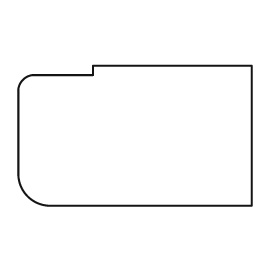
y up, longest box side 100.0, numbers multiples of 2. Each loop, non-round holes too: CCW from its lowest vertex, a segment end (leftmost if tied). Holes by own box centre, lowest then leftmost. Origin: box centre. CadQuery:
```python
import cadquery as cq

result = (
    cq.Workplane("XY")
    .moveTo(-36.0, -30.0)
    .lineTo(50.0, -30.0)
    .lineTo(50.0, 30.0)
    .lineTo(-18.0, 30.0)
    .lineTo(-18.0, 26.0)
    .lineTo(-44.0, 26.0)
    .threePointArc((-48.0, 24.0), (-50.0, 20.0))
    .lineTo(-50.0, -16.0)
    .threePointArc((-46.0, -26.0), (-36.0, -30.0))
    .close()
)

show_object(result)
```